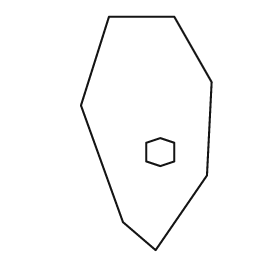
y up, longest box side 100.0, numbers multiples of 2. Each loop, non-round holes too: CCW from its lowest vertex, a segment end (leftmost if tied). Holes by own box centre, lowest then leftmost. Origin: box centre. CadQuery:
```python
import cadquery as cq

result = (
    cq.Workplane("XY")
    .moveTo(4.0, -50.0)
    .lineTo(26.0, -18.0)
    .lineTo(28.0, 22.0)
    .lineTo(12.0, 50.0)
    .lineTo(-16.0, 50.0)
    .lineTo(-28.0, 12.0)
    .lineTo(-10.0, -38.0)
    .close()
    .moveTo(6.0, -14.0)
    .lineTo(12.0, -12.0)
    .lineTo(12.0, -4.0)
    .lineTo(6.0, -2.0)
    .lineTo(0.0, -4.0)
    .lineTo(0.0, -12.0)
    .close()
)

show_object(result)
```